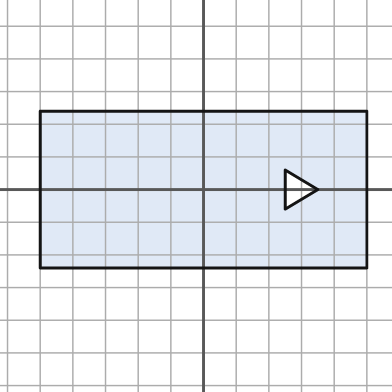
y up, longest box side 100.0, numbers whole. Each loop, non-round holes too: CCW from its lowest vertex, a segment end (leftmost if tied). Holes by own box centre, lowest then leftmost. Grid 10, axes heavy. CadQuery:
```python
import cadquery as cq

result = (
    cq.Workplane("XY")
    .moveTo(-50.0, -24.0)
    .lineTo(50.0, -24.0)
    .lineTo(50.0, 24.0)
    .lineTo(-50.0, 24.0)
    .close()
    .moveTo(25.0, -6.0)
    .lineTo(35.0, 0.0)
    .lineTo(25.0, 6.0)
    .close()
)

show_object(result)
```